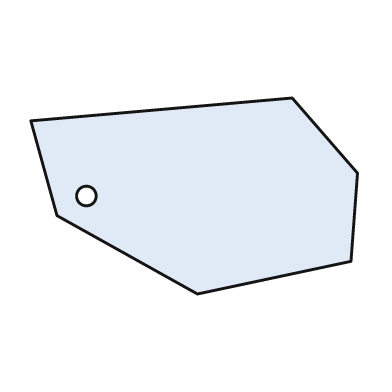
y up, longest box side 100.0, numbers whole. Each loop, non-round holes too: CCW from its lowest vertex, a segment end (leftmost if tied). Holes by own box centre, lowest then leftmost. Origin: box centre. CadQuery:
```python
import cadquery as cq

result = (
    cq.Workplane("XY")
    .moveTo(1.0, -30.0)
    .lineTo(48.0, -20.0)
    .lineTo(50.0, 7.0)
    .lineTo(30.0, 30.0)
    .lineTo(-50.0, 23.0)
    .lineTo(-42.0, -6.0)
    .close()
    .moveTo(-33.0, 0.0)
    .circle(3.0)
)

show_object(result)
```